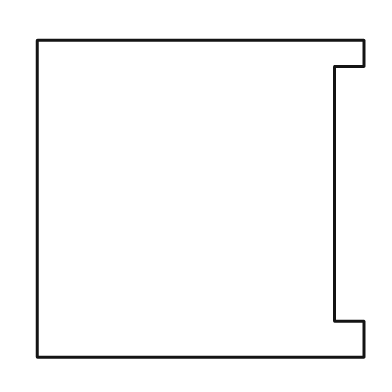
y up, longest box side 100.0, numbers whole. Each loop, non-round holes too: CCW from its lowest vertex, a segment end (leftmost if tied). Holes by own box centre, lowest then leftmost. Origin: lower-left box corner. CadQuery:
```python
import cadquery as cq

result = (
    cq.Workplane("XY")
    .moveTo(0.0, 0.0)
    .lineTo(100.0, 0.0)
    .lineTo(100.0, 11.0)
    .lineTo(91.0, 11.0)
    .lineTo(91.0, 89.0)
    .lineTo(100.0, 89.0)
    .lineTo(100.0, 97.0)
    .lineTo(0.0, 97.0)
    .close()
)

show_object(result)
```